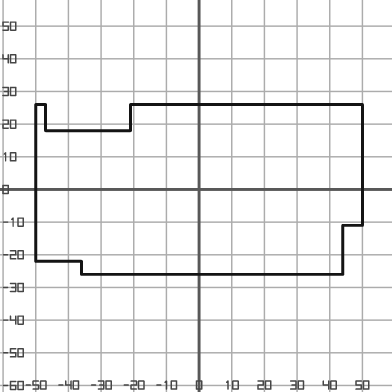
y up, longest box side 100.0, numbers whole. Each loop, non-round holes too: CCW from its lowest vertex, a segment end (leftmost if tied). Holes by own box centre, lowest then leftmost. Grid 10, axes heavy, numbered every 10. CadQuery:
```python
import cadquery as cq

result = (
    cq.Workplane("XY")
    .moveTo(-36.0, -26.0)
    .lineTo(44.0, -26.0)
    .lineTo(44.0, -11.0)
    .lineTo(50.0, -11.0)
    .lineTo(50.0, 26.0)
    .lineTo(-21.0, 26.0)
    .lineTo(-21.0, 18.0)
    .lineTo(-47.0, 18.0)
    .lineTo(-47.0, 26.0)
    .lineTo(-50.0, 26.0)
    .lineTo(-50.0, -22.0)
    .lineTo(-36.0, -22.0)
    .close()
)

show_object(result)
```